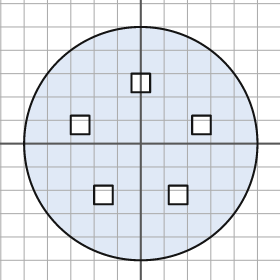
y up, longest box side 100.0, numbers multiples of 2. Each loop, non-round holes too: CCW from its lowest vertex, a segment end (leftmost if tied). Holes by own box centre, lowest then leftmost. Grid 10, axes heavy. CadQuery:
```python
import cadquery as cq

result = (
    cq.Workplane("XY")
    .moveTo(0.0, 0.0)
    .circle(50.0)
    .moveTo(-20.0, -26.0)
    .lineTo(-12.0, -26.0)
    .lineTo(-12.0, -18.0)
    .lineTo(-20.0, -18.0)
    .close()
    .moveTo(12.0, -26.0)
    .lineTo(20.0, -26.0)
    .lineTo(20.0, -18.0)
    .lineTo(12.0, -18.0)
    .close()
    .moveTo(-30.0, 4.0)
    .lineTo(-22.0, 4.0)
    .lineTo(-22.0, 12.0)
    .lineTo(-30.0, 12.0)
    .close()
    .moveTo(22.0, 4.0)
    .lineTo(30.0, 4.0)
    .lineTo(30.0, 12.0)
    .lineTo(22.0, 12.0)
    .close()
    .moveTo(-4.0, 22.0)
    .lineTo(4.0, 22.0)
    .lineTo(4.0, 30.0)
    .lineTo(-4.0, 30.0)
    .close()
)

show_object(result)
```